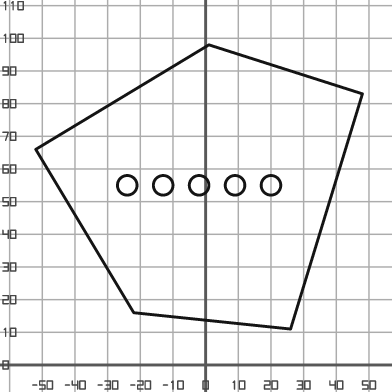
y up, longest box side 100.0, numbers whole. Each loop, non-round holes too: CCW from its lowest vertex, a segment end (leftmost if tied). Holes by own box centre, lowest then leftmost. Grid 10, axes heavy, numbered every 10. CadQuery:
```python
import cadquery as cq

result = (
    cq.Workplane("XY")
    .moveTo(26.0, 11.0)
    .lineTo(48.0, 83.0)
    .lineTo(1.0, 98.0)
    .lineTo(-52.0, 66.0)
    .lineTo(-22.0, 16.0)
    .close()
    .moveTo(-24.0, 55.0)
    .circle(3.0)
    .moveTo(-13.0, 55.0)
    .circle(3.0)
    .moveTo(-2.0, 55.0)
    .circle(3.0)
    .moveTo(9.0, 55.0)
    .circle(3.0)
    .moveTo(20.0, 55.0)
    .circle(3.0)
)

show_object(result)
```